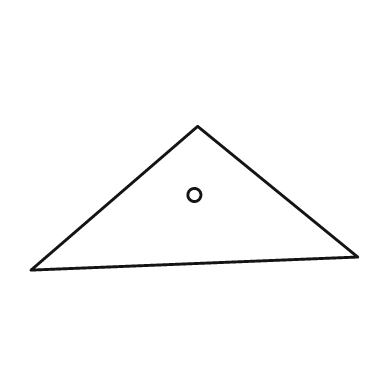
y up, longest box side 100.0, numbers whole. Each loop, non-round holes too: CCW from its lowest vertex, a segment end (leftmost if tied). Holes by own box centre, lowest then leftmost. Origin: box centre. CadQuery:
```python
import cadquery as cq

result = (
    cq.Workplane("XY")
    .moveTo(-50.0, -22.0)
    .lineTo(50.0, -18.0)
    .lineTo(1.0, 22.0)
    .close()
    .moveTo(0.0, 1.0)
    .circle(2.0)
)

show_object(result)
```